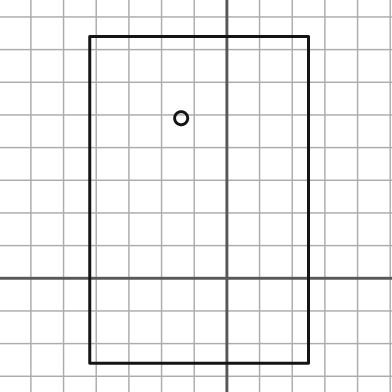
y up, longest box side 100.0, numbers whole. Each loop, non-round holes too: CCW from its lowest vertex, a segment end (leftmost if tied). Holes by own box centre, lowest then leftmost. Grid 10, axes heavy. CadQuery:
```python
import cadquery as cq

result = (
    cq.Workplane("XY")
    .moveTo(-42.0, -26.0)
    .lineTo(25.0, -26.0)
    .lineTo(25.0, 74.0)
    .lineTo(-42.0, 74.0)
    .close()
    .moveTo(-14.0, 49.0)
    .circle(2.0)
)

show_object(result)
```